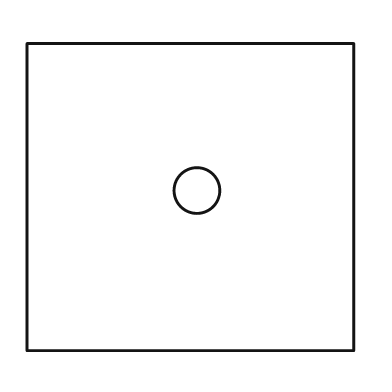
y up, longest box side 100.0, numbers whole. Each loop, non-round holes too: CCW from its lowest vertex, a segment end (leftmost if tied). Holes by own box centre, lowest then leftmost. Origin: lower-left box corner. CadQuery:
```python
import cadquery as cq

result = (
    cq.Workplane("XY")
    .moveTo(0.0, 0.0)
    .lineTo(100.0, 0.0)
    .lineTo(100.0, 94.0)
    .lineTo(0.0, 94.0)
    .close()
    .moveTo(52.0, 49.0)
    .circle(7.0)
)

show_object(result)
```